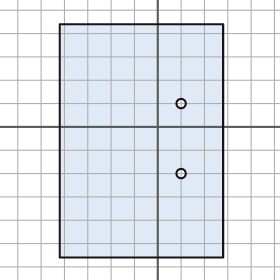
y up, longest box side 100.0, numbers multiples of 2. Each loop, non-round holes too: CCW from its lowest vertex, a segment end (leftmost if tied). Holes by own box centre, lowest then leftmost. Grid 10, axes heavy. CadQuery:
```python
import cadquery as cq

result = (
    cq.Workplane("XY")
    .moveTo(-42.0, -56.0)
    .lineTo(28.0, -56.0)
    .lineTo(28.0, 44.0)
    .lineTo(-42.0, 44.0)
    .close()
    .moveTo(10.0, -20.0)
    .circle(2.0)
    .moveTo(10.0, 10.0)
    .circle(2.0)
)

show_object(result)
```